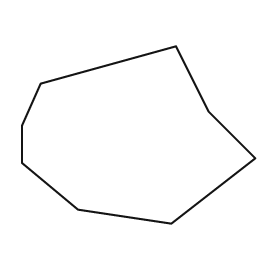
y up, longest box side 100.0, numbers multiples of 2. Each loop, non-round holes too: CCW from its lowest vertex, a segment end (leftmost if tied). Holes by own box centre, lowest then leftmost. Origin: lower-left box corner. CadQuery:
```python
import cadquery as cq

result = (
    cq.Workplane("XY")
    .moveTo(64.0, 0.0)
    .lineTo(100.0, 28.0)
    .lineTo(80.0, 48.0)
    .lineTo(66.0, 76.0)
    .lineTo(8.0, 60.0)
    .lineTo(0.0, 42.0)
    .lineTo(0.0, 26.0)
    .lineTo(24.0, 6.0)
    .close()
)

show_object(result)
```